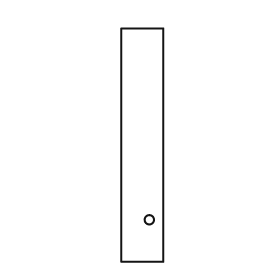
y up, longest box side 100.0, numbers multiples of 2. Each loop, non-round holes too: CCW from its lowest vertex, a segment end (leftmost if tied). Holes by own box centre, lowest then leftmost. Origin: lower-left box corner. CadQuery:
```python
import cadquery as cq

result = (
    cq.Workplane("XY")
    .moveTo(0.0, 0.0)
    .lineTo(18.0, 0.0)
    .lineTo(18.0, 100.0)
    .lineTo(0.0, 100.0)
    .close()
    .moveTo(12.0, 18.0)
    .circle(2.0)
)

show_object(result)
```